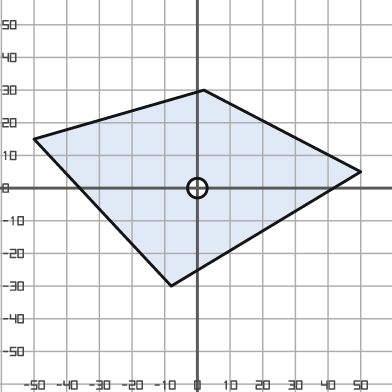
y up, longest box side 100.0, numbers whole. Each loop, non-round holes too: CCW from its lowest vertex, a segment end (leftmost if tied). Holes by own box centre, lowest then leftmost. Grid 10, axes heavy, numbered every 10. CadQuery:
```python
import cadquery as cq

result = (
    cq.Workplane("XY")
    .moveTo(-8.0, -30.0)
    .lineTo(50.0, 5.0)
    .lineTo(2.0, 30.0)
    .lineTo(-50.0, 15.0)
    .close()
    .moveTo(0.0, 0.0)
    .circle(3.0)
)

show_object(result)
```